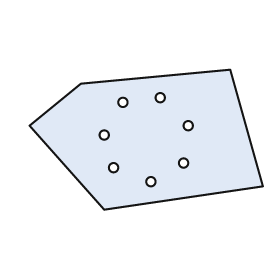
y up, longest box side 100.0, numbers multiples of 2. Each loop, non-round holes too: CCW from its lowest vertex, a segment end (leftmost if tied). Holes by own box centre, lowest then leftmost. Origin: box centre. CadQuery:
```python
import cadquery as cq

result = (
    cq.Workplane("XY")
    .moveTo(-18.0, -30.0)
    .lineTo(50.0, -20.0)
    .lineTo(36.0, 30.0)
    .lineTo(-28.0, 24.0)
    .lineTo(-50.0, 6.0)
    .close()
    .moveTo(2.0, -18.0)
    .circle(2.0)
    .moveTo(-14.0, -12.0)
    .circle(2.0)
    .moveTo(16.0, -10.0)
    .circle(2.0)
    .moveTo(-18.0, 2.0)
    .circle(2.0)
    .moveTo(18.0, 6.0)
    .circle(2.0)
    .moveTo(-10.0, 16.0)
    .circle(2.0)
    .moveTo(6.0, 18.0)
    .circle(2.0)
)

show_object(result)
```